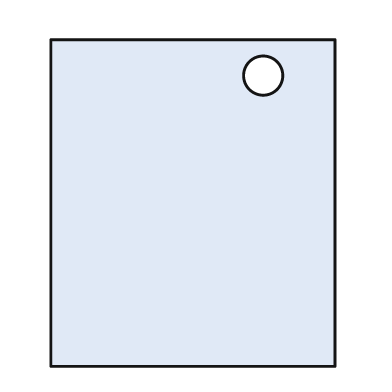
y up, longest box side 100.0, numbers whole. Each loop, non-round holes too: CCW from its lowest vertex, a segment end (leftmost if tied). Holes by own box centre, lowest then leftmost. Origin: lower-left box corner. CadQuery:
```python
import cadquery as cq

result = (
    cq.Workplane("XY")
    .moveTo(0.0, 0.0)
    .lineTo(87.0, 0.0)
    .lineTo(87.0, 100.0)
    .lineTo(0.0, 100.0)
    .close()
    .moveTo(65.0, 89.0)
    .circle(6.0)
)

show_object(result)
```